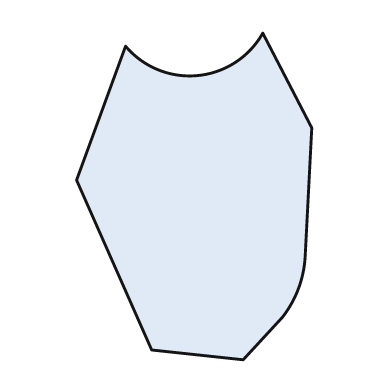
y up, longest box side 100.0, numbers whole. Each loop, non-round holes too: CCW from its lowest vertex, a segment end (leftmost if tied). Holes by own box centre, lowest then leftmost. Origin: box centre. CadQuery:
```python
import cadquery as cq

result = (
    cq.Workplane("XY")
    .moveTo(15.0, -50.0)
    .lineTo(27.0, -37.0)
    .threePointArc((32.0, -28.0), (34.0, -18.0))
    .lineTo(36.0, 21.0)
    .lineTo(21.0, 50.0)
    .threePointArc((1.0, 37.0), (-21.0, 46.0))
    .lineTo(-36.0, 5.0)
    .lineTo(-13.0, -47.0)
    .close()
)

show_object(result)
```